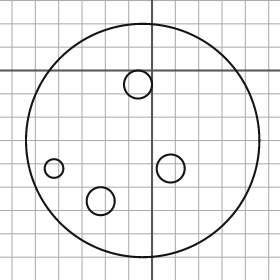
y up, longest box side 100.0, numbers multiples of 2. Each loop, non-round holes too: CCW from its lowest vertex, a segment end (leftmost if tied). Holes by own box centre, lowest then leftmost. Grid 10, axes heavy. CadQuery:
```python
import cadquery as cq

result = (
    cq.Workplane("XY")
    .moveTo(-4.0, -30.0)
    .circle(50.0)
    .moveTo(-22.0, -56.0)
    .circle(6.0)
    .moveTo(-42.0, -42.0)
    .circle(4.0)
    .moveTo(8.0, -42.0)
    .circle(6.0)
    .moveTo(-6.0, -6.0)
    .circle(6.0)
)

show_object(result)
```